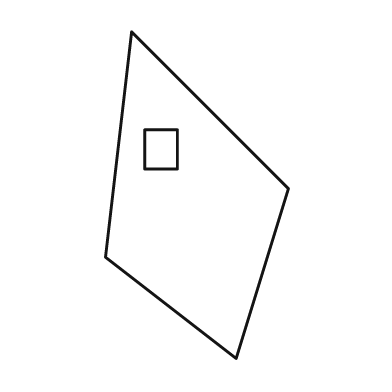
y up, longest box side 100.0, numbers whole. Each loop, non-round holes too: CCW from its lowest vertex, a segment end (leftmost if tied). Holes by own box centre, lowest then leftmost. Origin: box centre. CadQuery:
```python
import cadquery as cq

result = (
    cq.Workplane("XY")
    .moveTo(12.0, -50.0)
    .lineTo(28.0, 2.0)
    .lineTo(-20.0, 50.0)
    .lineTo(-28.0, -19.0)
    .close()
    .moveTo(-16.0, 8.0)
    .lineTo(-6.0, 8.0)
    .lineTo(-6.0, 20.0)
    .lineTo(-16.0, 20.0)
    .close()
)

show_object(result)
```